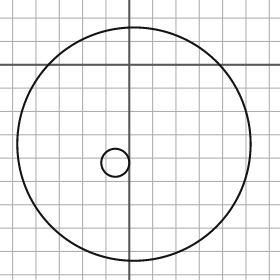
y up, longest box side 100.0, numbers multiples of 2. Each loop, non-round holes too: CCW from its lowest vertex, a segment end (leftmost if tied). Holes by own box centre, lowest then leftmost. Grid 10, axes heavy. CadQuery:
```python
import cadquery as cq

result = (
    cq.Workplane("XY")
    .moveTo(2.0, -34.0)
    .circle(50.0)
    .moveTo(-6.0, -42.0)
    .circle(6.0)
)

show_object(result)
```